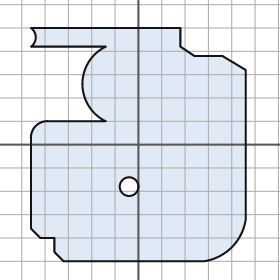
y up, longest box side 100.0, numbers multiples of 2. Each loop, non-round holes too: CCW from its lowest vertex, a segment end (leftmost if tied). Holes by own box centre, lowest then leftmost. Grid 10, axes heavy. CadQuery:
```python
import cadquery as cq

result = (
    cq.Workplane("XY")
    .moveTo(-32.0, -50.0)
    .lineTo(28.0, -50.0)
    .threePointArc((40.0, -44.0), (46.0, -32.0))
    .lineTo(46.0, 32.0)
    .lineTo(36.0, 38.0)
    .lineTo(24.0, 38.0)
    .lineTo(18.0, 42.0)
    .lineTo(18.0, 50.0)
    .lineTo(-46.0, 50.0)
    .threePointArc((-44.0, 46.0), (-46.0, 42.0))
    .lineTo(-14.0, 42.0)
    .threePointArc((-24.0, 26.0), (-14.0, 10.0))
    .lineTo(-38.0, 10.0)
    .threePointArc((-44.0, 8.0), (-46.0, 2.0))
    .lineTo(-46.0, -36.0)
    .lineTo(-42.0, -40.0)
    .lineTo(-36.0, -40.0)
    .lineTo(-36.0, -46.0)
    .close()
    .moveTo(-4.0, -18.0)
    .circle(4.0)
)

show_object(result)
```